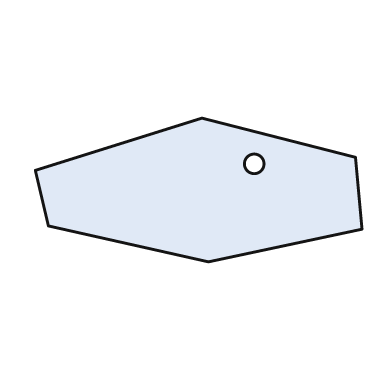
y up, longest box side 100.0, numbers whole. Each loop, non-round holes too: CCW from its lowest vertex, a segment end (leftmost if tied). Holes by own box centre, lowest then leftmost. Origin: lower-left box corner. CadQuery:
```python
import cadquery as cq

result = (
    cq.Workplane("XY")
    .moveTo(53.0, 0.0)
    .lineTo(100.0, 10.0)
    .lineTo(98.0, 32.0)
    .lineTo(51.0, 44.0)
    .lineTo(0.0, 28.0)
    .lineTo(4.0, 11.0)
    .close()
    .moveTo(67.0, 30.0)
    .circle(3.0)
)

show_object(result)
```